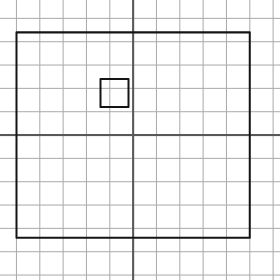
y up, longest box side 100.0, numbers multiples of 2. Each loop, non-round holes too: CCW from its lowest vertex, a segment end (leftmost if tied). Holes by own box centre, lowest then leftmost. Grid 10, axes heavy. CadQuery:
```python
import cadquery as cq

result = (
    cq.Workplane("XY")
    .moveTo(-50.0, -44.0)
    .lineTo(50.0, -44.0)
    .lineTo(50.0, 44.0)
    .lineTo(-50.0, 44.0)
    .close()
    .moveTo(-14.0, 12.0)
    .lineTo(-2.0, 12.0)
    .lineTo(-2.0, 24.0)
    .lineTo(-14.0, 24.0)
    .close()
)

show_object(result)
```